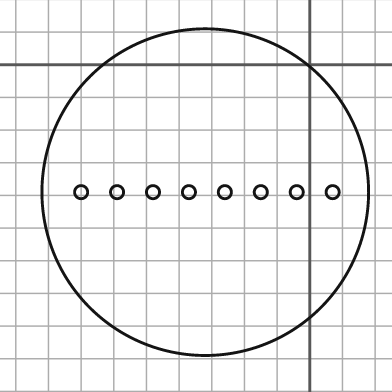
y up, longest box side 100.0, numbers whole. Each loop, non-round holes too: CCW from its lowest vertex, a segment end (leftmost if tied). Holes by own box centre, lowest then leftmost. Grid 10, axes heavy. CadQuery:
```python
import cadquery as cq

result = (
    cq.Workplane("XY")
    .moveTo(-32.0, -39.0)
    .circle(50.0)
    .moveTo(-70.0, -39.0)
    .circle(2.0)
    .moveTo(-59.0, -39.0)
    .circle(2.0)
    .moveTo(-48.0, -39.0)
    .circle(2.0)
    .moveTo(-37.0, -39.0)
    .circle(2.0)
    .moveTo(-26.0, -39.0)
    .circle(2.0)
    .moveTo(-15.0, -39.0)
    .circle(2.0)
    .moveTo(-4.0, -39.0)
    .circle(2.0)
    .moveTo(7.0, -39.0)
    .circle(2.0)
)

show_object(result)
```